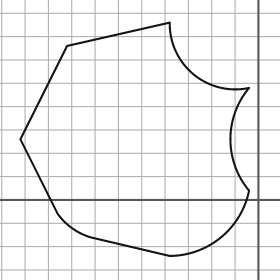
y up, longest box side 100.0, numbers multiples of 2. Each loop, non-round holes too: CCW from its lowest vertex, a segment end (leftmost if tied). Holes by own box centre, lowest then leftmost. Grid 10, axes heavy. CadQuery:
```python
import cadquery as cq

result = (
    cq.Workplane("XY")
    .moveTo(-38.0, -24.0)
    .threePointArc((-16.0, -16.0), (-4.0, 4.0))
    .threePointArc((-12.0, 26.0), (-4.0, 48.0))
    .threePointArc((-28.0, 54.0), (-38.0, 76.0))
    .lineTo(-82.0, 66.0)
    .lineTo(-102.0, 26.0)
    .lineTo(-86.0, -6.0)
    .threePointArc((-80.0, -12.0), (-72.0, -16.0))
    .close()
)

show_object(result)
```